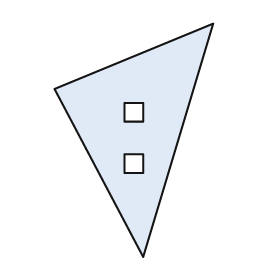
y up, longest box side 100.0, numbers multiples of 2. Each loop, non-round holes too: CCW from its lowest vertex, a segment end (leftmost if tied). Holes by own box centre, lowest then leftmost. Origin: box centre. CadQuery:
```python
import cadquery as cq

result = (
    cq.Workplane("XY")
    .moveTo(4.0, -50.0)
    .lineTo(34.0, 50.0)
    .lineTo(-34.0, 22.0)
    .close()
    .moveTo(-4.0, -14.0)
    .lineTo(4.0, -14.0)
    .lineTo(4.0, -6.0)
    .lineTo(-4.0, -6.0)
    .close()
    .moveTo(-4.0, 8.0)
    .lineTo(4.0, 8.0)
    .lineTo(4.0, 16.0)
    .lineTo(-4.0, 16.0)
    .close()
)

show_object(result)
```